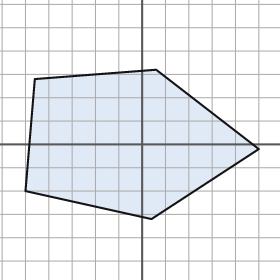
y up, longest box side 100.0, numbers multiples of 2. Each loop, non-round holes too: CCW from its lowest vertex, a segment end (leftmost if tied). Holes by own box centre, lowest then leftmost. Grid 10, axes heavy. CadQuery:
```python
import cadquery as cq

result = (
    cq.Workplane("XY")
    .moveTo(4.0, -32.0)
    .lineTo(50.0, -2.0)
    .lineTo(6.0, 32.0)
    .lineTo(-46.0, 28.0)
    .lineTo(-50.0, -20.0)
    .close()
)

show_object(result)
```